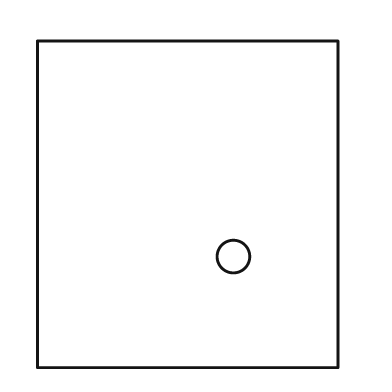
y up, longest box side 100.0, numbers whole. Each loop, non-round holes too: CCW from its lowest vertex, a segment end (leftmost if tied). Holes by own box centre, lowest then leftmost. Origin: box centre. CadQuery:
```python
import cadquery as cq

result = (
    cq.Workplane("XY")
    .moveTo(-46.0, -50.0)
    .lineTo(46.0, -50.0)
    .lineTo(46.0, 50.0)
    .lineTo(-46.0, 50.0)
    .close()
    .moveTo(14.0, -16.0)
    .circle(5.0)
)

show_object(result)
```